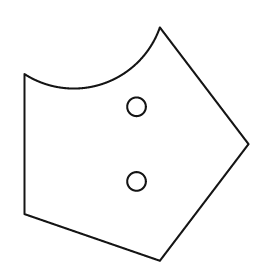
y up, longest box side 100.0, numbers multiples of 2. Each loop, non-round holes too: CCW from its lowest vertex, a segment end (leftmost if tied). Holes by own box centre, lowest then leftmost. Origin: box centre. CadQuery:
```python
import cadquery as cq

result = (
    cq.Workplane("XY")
    .moveTo(10.0, -50.0)
    .lineTo(48.0, 0.0)
    .lineTo(10.0, 50.0)
    .threePointArc((-14.0, 26.0), (-48.0, 30.0))
    .lineTo(-48.0, -30.0)
    .close()
    .moveTo(0.0, -16.0)
    .circle(4.0)
    .moveTo(0.0, 16.0)
    .circle(4.0)
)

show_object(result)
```